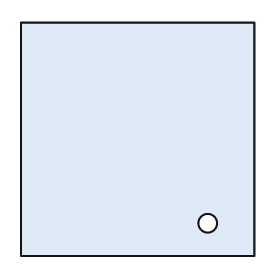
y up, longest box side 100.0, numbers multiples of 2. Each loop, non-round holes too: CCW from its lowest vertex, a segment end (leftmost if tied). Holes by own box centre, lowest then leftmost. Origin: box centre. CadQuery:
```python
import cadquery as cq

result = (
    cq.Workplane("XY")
    .moveTo(-50.0, -50.0)
    .lineTo(50.0, -50.0)
    .lineTo(50.0, 50.0)
    .lineTo(-50.0, 50.0)
    .close()
    .moveTo(30.0, -36.0)
    .circle(4.0)
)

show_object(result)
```